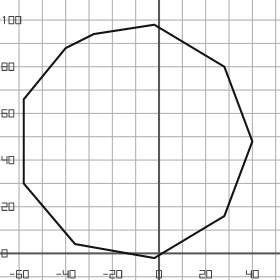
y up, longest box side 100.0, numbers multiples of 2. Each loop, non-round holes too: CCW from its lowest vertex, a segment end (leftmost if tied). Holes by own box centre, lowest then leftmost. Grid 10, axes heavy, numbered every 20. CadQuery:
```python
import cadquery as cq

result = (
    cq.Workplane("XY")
    .moveTo(-2.0, -2.0)
    .lineTo(28.0, 16.0)
    .lineTo(40.0, 48.0)
    .lineTo(28.0, 80.0)
    .lineTo(-2.0, 98.0)
    .lineTo(-28.0, 94.0)
    .lineTo(-40.0, 88.0)
    .lineTo(-58.0, 66.0)
    .lineTo(-58.0, 30.0)
    .lineTo(-36.0, 4.0)
    .close()
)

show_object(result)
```